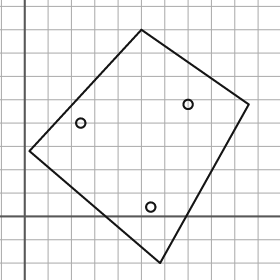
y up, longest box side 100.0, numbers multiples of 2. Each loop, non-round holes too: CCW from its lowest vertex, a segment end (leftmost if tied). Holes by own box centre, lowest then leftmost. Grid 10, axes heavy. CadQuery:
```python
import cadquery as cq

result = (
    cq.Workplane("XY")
    .moveTo(58.0, -20.0)
    .lineTo(96.0, 48.0)
    .lineTo(50.0, 80.0)
    .lineTo(2.0, 28.0)
    .close()
    .moveTo(54.0, 4.0)
    .circle(2.0)
    .moveTo(24.0, 40.0)
    .circle(2.0)
    .moveTo(70.0, 48.0)
    .circle(2.0)
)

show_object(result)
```